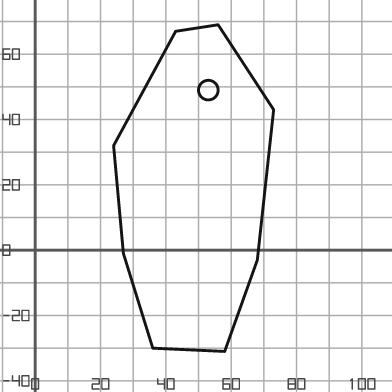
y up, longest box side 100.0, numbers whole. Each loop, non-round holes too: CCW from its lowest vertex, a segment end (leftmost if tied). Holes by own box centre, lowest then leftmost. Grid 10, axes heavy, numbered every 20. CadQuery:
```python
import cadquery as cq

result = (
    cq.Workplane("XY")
    .moveTo(58.0, -31.0)
    .lineTo(68.0, -3.0)
    .lineTo(73.0, 43.0)
    .lineTo(56.0, 69.0)
    .lineTo(43.0, 67.0)
    .lineTo(24.0, 32.0)
    .lineTo(27.0, -1.0)
    .lineTo(36.0, -30.0)
    .close()
    .moveTo(53.0, 49.0)
    .circle(3.0)
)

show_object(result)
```